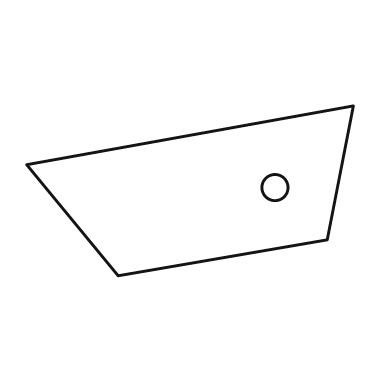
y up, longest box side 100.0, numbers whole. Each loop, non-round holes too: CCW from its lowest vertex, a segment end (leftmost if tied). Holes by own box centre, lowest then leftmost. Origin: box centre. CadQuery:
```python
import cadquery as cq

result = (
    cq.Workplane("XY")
    .moveTo(-22.0, -26.0)
    .lineTo(42.0, -15.0)
    .lineTo(50.0, 26.0)
    .lineTo(-50.0, 8.0)
    .close()
    .moveTo(26.0, 1.0)
    .circle(4.0)
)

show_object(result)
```